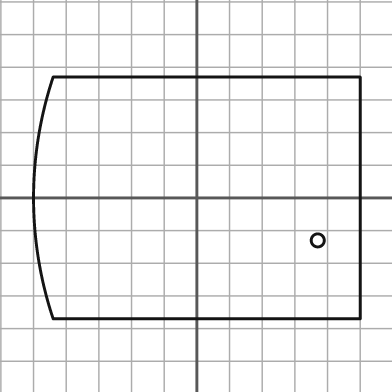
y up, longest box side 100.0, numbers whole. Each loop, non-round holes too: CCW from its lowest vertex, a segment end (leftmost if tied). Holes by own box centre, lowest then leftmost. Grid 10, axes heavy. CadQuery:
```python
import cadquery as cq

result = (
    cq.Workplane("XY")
    .moveTo(-44.0, -37.0)
    .lineTo(50.0, -37.0)
    .lineTo(50.0, 37.0)
    .lineTo(-44.0, 37.0)
    .threePointArc((-50.0, 0.0), (-44.0, -37.0))
    .close()
    .moveTo(37.0, -13.0)
    .circle(2.0)
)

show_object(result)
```